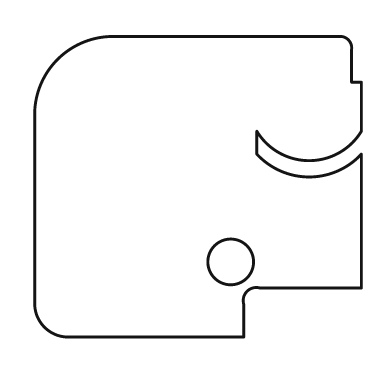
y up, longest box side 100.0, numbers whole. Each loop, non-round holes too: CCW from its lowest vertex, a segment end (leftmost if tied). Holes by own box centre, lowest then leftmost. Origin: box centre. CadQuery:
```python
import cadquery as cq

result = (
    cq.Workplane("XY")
    .moveTo(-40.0, -46.0)
    .lineTo(14.0, -46.0)
    .lineTo(14.0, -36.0)
    .threePointArc((15.0, -32.0), (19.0, -31.0))
    .lineTo(50.0, -31.0)
    .lineTo(50.0, 10.0)
    .threePointArc((34.0, 3.0), (18.0, 10.0))
    .lineTo(18.0, 17.0)
    .threePointArc((34.0, 8.0), (50.0, 17.0))
    .lineTo(50.0, 32.0)
    .lineTo(47.0, 32.0)
    .lineTo(47.0, 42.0)
    .threePointArc((46.0, 45.0), (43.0, 46.0))
    .lineTo(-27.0, 46.0)
    .threePointArc((-43.0, 39.0), (-50.0, 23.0))
    .lineTo(-50.0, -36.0)
    .threePointArc((-47.0, -43.0), (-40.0, -46.0))
    .close()
    .moveTo(10.0, -23.0)
    .circle(7.0)
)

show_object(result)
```